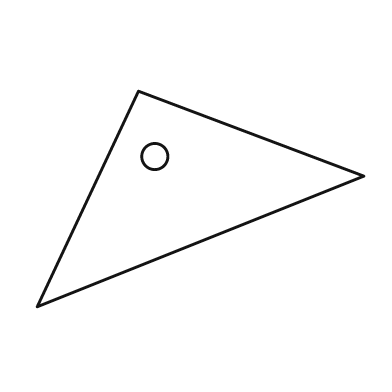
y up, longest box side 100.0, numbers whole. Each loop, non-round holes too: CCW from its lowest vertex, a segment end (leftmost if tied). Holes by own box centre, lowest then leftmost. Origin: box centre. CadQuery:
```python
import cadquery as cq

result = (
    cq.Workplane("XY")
    .moveTo(-50.0, -33.0)
    .lineTo(50.0, 7.0)
    .lineTo(-19.0, 33.0)
    .close()
    .moveTo(-14.0, 13.0)
    .circle(4.0)
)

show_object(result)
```